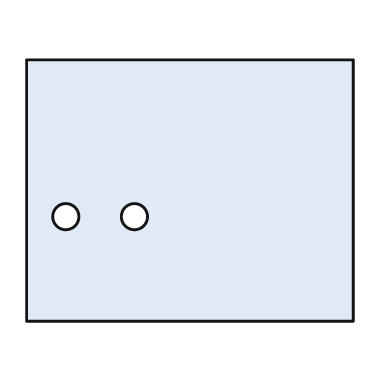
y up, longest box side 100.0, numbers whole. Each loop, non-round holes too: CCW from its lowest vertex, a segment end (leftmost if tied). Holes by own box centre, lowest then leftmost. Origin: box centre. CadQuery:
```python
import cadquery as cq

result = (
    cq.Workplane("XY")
    .moveTo(-50.0, -40.0)
    .lineTo(50.0, -40.0)
    .lineTo(50.0, 40.0)
    .lineTo(-50.0, 40.0)
    .close()
    .moveTo(-38.0, -8.0)
    .circle(4.0)
    .moveTo(-17.0, -8.0)
    .circle(4.0)
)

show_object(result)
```